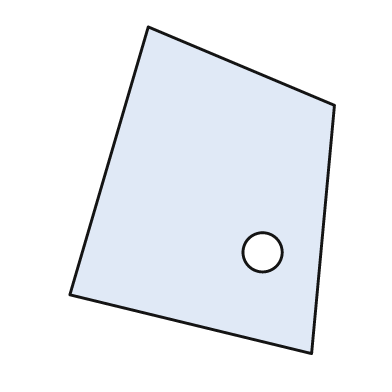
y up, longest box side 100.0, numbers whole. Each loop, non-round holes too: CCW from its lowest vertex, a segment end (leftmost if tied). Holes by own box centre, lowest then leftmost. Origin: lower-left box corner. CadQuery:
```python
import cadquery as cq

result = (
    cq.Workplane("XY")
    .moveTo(74.0, 0.0)
    .lineTo(81.0, 76.0)
    .lineTo(24.0, 100.0)
    .lineTo(0.0, 18.0)
    .close()
    .moveTo(59.0, 31.0)
    .circle(6.0)
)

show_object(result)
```